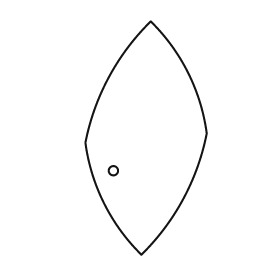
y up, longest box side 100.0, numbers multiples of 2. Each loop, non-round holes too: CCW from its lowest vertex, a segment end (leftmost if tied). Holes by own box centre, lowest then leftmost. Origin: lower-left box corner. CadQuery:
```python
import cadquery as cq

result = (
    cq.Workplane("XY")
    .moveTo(24.0, 0.0)
    .threePointArc((42.0, 24.0), (52.0, 52.0))
    .threePointArc((44.0, 78.0), (28.0, 100.0))
    .threePointArc((10.0, 76.0), (0.0, 48.0))
    .threePointArc((8.0, 22.0), (24.0, 0.0))
    .close()
    .moveTo(12.0, 36.0)
    .circle(2.0)
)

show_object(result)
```